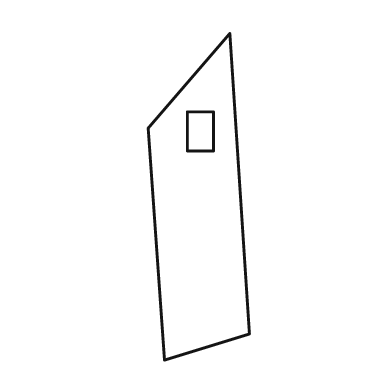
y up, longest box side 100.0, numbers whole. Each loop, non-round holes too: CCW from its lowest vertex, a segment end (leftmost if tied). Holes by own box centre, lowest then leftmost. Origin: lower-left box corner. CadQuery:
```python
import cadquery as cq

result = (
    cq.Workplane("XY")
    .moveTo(5.0, 0.0)
    .lineTo(31.0, 8.0)
    .lineTo(25.0, 100.0)
    .lineTo(0.0, 71.0)
    .close()
    .moveTo(12.0, 64.0)
    .lineTo(20.0, 64.0)
    .lineTo(20.0, 76.0)
    .lineTo(12.0, 76.0)
    .close()
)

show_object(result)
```